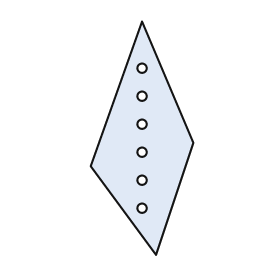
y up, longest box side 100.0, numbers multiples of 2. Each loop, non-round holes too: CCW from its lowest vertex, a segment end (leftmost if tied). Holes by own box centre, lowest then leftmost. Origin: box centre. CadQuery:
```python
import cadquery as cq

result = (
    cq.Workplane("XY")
    .moveTo(6.0, -50.0)
    .lineTo(22.0, -2.0)
    .lineTo(0.0, 50.0)
    .lineTo(-22.0, -12.0)
    .close()
    .moveTo(0.0, -30.0)
    .circle(2.0)
    .moveTo(0.0, -18.0)
    .circle(2.0)
    .moveTo(0.0, -6.0)
    .circle(2.0)
    .moveTo(0.0, 6.0)
    .circle(2.0)
    .moveTo(0.0, 18.0)
    .circle(2.0)
    .moveTo(0.0, 30.0)
    .circle(2.0)
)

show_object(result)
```